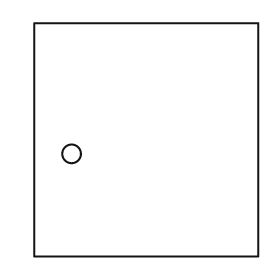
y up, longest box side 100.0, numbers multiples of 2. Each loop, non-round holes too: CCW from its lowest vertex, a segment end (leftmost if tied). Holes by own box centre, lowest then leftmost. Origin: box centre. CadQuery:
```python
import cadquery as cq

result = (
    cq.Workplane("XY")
    .moveTo(-48.0, -50.0)
    .lineTo(48.0, -50.0)
    .lineTo(48.0, 50.0)
    .lineTo(-48.0, 50.0)
    .close()
    .moveTo(-32.0, -6.0)
    .circle(4.0)
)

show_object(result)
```